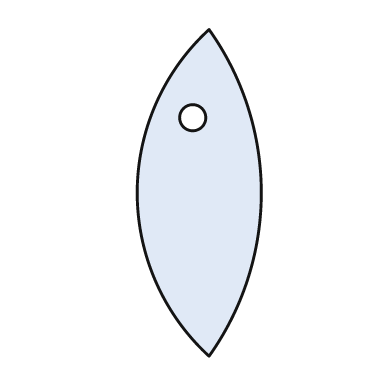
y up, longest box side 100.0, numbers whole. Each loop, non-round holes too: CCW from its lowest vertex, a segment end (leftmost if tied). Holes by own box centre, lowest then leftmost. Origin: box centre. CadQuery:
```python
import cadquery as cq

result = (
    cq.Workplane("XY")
    .moveTo(3.0, -50.0)
    .threePointArc((19.0, 0.0), (3.0, 50.0))
    .threePointArc((-19.0, 0.0), (3.0, -50.0))
    .close()
    .moveTo(-2.0, 23.0)
    .circle(4.0)
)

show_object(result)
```